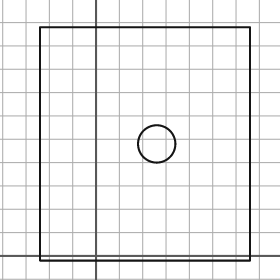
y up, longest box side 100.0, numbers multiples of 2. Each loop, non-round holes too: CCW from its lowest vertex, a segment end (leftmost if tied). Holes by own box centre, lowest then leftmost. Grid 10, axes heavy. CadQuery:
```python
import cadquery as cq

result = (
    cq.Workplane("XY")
    .moveTo(-24.0, -2.0)
    .lineTo(66.0, -2.0)
    .lineTo(66.0, 98.0)
    .lineTo(-24.0, 98.0)
    .close()
    .moveTo(26.0, 48.0)
    .circle(8.0)
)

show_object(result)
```